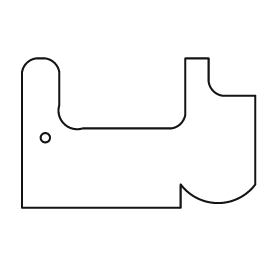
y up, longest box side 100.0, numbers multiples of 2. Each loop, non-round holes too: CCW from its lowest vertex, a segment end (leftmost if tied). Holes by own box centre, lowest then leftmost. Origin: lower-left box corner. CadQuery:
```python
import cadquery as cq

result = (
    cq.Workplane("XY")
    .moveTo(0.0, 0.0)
    .lineTo(68.0, 0.0)
    .lineTo(68.0, 10.0)
    .threePointArc((84.0, 2.0), (100.0, 10.0))
    .lineTo(100.0, 48.0)
    .lineTo(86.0, 48.0)
    .threePointArc((82.0, 50.0), (80.0, 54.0))
    .lineTo(80.0, 64.0)
    .lineTo(70.0, 64.0)
    .lineTo(70.0, 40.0)
    .threePointArc((68.0, 36.0), (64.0, 34.0))
    .lineTo(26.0, 34.0)
    .threePointArc((18.0, 36.0), (16.0, 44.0))
    .lineTo(16.0, 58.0)
    .threePointArc((14.0, 62.0), (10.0, 64.0))
    .lineTo(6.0, 64.0)
    .threePointArc((2.0, 62.0), (0.0, 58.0))
    .close()
    .moveTo(10.0, 30.0)
    .circle(2.0)
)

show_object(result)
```